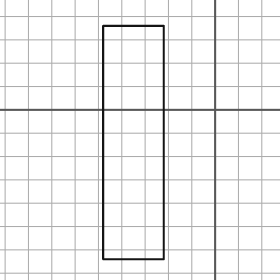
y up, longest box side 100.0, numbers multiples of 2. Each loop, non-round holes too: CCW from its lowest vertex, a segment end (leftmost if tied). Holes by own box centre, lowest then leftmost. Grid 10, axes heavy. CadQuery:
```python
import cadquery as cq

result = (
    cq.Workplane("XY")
    .moveTo(-48.0, -64.0)
    .lineTo(-22.0, -64.0)
    .lineTo(-22.0, 36.0)
    .lineTo(-48.0, 36.0)
    .close()
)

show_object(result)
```